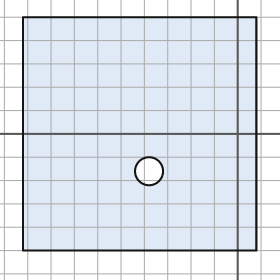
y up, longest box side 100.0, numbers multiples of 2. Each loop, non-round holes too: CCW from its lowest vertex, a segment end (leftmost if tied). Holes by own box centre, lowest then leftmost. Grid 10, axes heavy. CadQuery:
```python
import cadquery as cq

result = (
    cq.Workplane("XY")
    .moveTo(-92.0, -50.0)
    .lineTo(8.0, -50.0)
    .lineTo(8.0, 50.0)
    .lineTo(-92.0, 50.0)
    .close()
    .moveTo(-38.0, -16.0)
    .circle(6.0)
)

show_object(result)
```